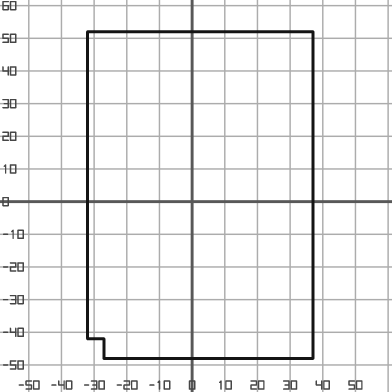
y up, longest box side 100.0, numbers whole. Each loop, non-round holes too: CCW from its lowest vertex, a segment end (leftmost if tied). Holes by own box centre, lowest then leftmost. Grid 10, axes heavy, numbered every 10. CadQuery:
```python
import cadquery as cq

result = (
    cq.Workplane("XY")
    .moveTo(-27.0, -48.0)
    .lineTo(37.0, -48.0)
    .lineTo(37.0, 52.0)
    .lineTo(-32.0, 52.0)
    .lineTo(-32.0, -42.0)
    .lineTo(-27.0, -42.0)
    .close()
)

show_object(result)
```